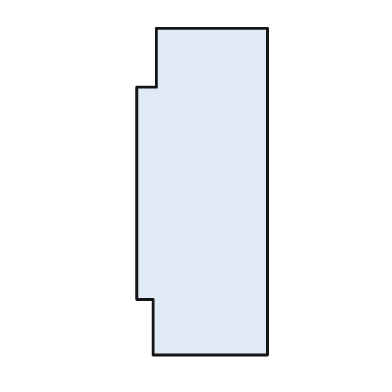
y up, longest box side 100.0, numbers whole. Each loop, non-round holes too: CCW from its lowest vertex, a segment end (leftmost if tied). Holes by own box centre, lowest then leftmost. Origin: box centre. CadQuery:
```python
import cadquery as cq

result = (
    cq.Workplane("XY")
    .moveTo(-15.0, -50.0)
    .lineTo(20.0, -50.0)
    .lineTo(20.0, 50.0)
    .lineTo(-14.0, 50.0)
    .lineTo(-14.0, 32.0)
    .lineTo(-20.0, 32.0)
    .lineTo(-20.0, -33.0)
    .lineTo(-15.0, -33.0)
    .close()
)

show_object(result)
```